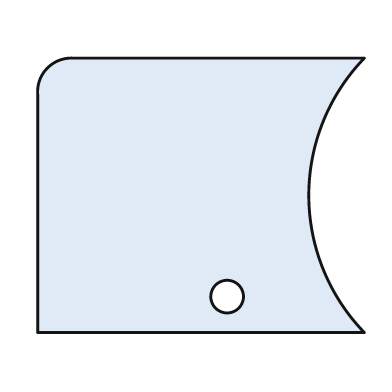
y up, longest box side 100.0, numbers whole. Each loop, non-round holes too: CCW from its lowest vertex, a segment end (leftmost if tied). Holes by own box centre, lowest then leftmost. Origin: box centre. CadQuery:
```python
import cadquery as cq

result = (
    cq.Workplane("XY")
    .moveTo(-50.0, -42.0)
    .lineTo(50.0, -42.0)
    .threePointArc((33.0, 0.0), (50.0, 42.0))
    .lineTo(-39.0, 42.0)
    .threePointArc((-47.0, 39.0), (-50.0, 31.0))
    .close()
    .moveTo(8.0, -31.0)
    .circle(5.0)
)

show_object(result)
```